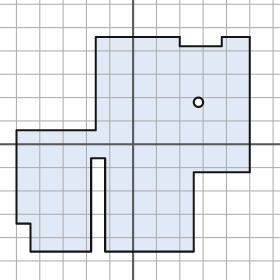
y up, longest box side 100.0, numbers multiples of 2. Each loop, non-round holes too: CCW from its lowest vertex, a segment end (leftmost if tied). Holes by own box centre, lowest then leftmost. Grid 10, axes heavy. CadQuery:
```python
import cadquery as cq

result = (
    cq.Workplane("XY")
    .moveTo(-44.0, -46.0)
    .lineTo(-18.0, -46.0)
    .lineTo(-18.0, -6.0)
    .lineTo(-12.0, -6.0)
    .lineTo(-12.0, -46.0)
    .lineTo(26.0, -46.0)
    .lineTo(26.0, -12.0)
    .lineTo(50.0, -12.0)
    .lineTo(50.0, 46.0)
    .lineTo(38.0, 46.0)
    .lineTo(38.0, 42.0)
    .lineTo(20.0, 42.0)
    .lineTo(20.0, 46.0)
    .lineTo(-16.0, 46.0)
    .lineTo(-16.0, 6.0)
    .lineTo(-50.0, 6.0)
    .lineTo(-50.0, -34.0)
    .lineTo(-44.0, -34.0)
    .close()
    .moveTo(28.0, 18.0)
    .circle(2.0)
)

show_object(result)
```